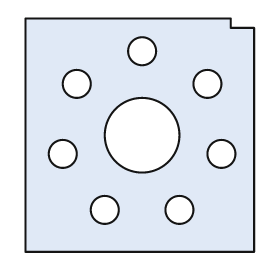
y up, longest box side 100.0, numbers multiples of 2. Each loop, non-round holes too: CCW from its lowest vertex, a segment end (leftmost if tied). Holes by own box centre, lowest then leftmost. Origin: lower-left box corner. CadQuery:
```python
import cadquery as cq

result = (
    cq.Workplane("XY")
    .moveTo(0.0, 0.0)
    .lineTo(98.0, 0.0)
    .lineTo(98.0, 96.0)
    .lineTo(88.0, 96.0)
    .lineTo(88.0, 100.0)
    .lineTo(0.0, 100.0)
    .close()
    .moveTo(34.0, 18.0)
    .circle(6.0)
    .moveTo(66.0, 18.0)
    .circle(6.0)
    .moveTo(16.0, 42.0)
    .circle(6.0)
    .moveTo(84.0, 42.0)
    .circle(6.0)
    .moveTo(50.0, 50.0)
    .circle(16.0)
    .moveTo(22.0, 72.0)
    .circle(6.0)
    .moveTo(78.0, 72.0)
    .circle(6.0)
    .moveTo(50.0, 86.0)
    .circle(6.0)
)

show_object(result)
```